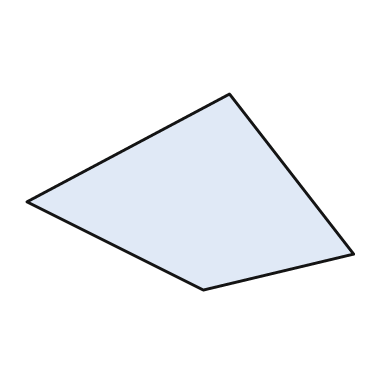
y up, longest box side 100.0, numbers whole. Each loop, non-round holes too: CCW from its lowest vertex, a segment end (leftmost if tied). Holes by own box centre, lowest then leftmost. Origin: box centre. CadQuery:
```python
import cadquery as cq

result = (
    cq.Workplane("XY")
    .moveTo(4.0, -30.0)
    .lineTo(50.0, -19.0)
    .lineTo(12.0, 30.0)
    .lineTo(-50.0, -3.0)
    .close()
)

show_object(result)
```